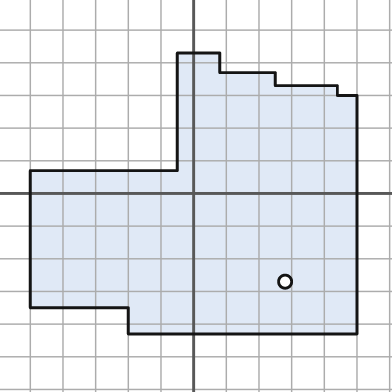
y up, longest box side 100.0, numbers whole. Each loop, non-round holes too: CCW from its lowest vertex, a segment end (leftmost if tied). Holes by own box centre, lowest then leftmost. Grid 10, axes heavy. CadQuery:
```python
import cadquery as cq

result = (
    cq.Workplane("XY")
    .moveTo(-20.0, -43.0)
    .lineTo(50.0, -43.0)
    .lineTo(50.0, 30.0)
    .lineTo(44.0, 30.0)
    .lineTo(44.0, 33.0)
    .lineTo(25.0, 33.0)
    .lineTo(25.0, 37.0)
    .lineTo(8.0, 37.0)
    .lineTo(8.0, 43.0)
    .lineTo(-5.0, 43.0)
    .lineTo(-5.0, 7.0)
    .lineTo(-50.0, 7.0)
    .lineTo(-50.0, -35.0)
    .lineTo(-20.0, -35.0)
    .close()
    .moveTo(28.0, -27.0)
    .circle(2.0)
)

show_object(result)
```